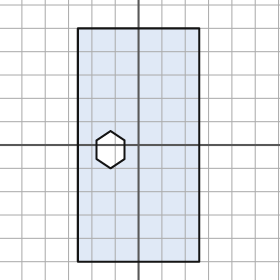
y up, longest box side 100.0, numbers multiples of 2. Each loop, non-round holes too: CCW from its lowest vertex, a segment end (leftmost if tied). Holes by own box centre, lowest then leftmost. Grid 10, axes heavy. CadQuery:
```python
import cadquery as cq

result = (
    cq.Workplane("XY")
    .moveTo(-26.0, -50.0)
    .lineTo(26.0, -50.0)
    .lineTo(26.0, 50.0)
    .lineTo(-26.0, 50.0)
    .close()
    .moveTo(-12.0, -10.0)
    .lineTo(-6.0, -6.0)
    .lineTo(-6.0, 2.0)
    .lineTo(-12.0, 6.0)
    .lineTo(-18.0, 2.0)
    .lineTo(-18.0, -6.0)
    .close()
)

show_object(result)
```